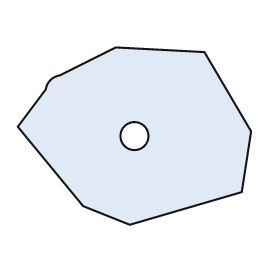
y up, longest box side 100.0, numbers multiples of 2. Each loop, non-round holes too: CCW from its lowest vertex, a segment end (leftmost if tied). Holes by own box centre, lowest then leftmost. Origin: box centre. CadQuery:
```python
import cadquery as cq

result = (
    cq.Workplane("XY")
    .moveTo(-2.0, -38.0)
    .lineTo(46.0, -24.0)
    .lineTo(50.0, 2.0)
    .lineTo(30.0, 36.0)
    .lineTo(-8.0, 38.0)
    .lineTo(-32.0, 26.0)
    .threePointArc((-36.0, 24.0), (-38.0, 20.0))
    .lineTo(-50.0, 4.0)
    .lineTo(-22.0, -30.0)
    .close()
    .moveTo(0.0, 0.0)
    .circle(6.0)
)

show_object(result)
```